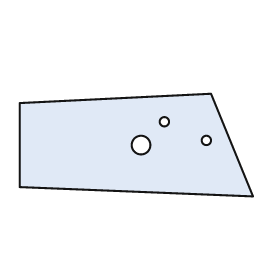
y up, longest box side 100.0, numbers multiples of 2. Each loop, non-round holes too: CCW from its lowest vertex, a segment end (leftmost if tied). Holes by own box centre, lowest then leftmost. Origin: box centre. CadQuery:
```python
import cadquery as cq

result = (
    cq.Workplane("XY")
    .moveTo(50.0, -22.0)
    .lineTo(32.0, 22.0)
    .lineTo(-50.0, 18.0)
    .lineTo(-50.0, -18.0)
    .close()
    .moveTo(2.0, 0.0)
    .circle(4.0)
    .moveTo(30.0, 2.0)
    .circle(2.0)
    .moveTo(12.0, 10.0)
    .circle(2.0)
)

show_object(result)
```